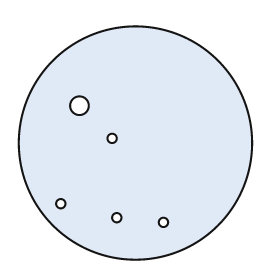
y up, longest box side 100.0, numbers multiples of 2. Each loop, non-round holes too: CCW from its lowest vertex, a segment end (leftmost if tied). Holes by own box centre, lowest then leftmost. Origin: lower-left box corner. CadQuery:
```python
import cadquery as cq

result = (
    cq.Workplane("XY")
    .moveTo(50.0, 50.0)
    .circle(50.0)
    .moveTo(62.0, 16.0)
    .circle(2.0)
    .moveTo(42.0, 18.0)
    .circle(2.0)
    .moveTo(18.0, 24.0)
    .circle(2.0)
    .moveTo(40.0, 52.0)
    .circle(2.0)
    .moveTo(26.0, 66.0)
    .circle(4.0)
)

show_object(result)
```